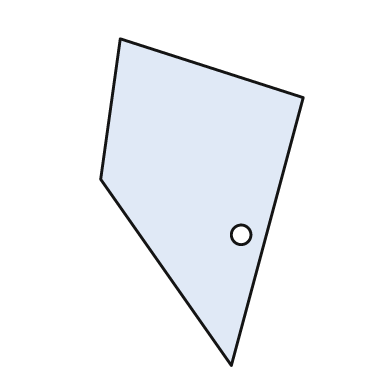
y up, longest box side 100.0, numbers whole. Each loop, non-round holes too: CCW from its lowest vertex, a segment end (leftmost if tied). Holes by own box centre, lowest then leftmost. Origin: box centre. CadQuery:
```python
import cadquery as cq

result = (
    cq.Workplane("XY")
    .moveTo(9.0, -50.0)
    .lineTo(31.0, 32.0)
    .lineTo(-25.0, 50.0)
    .lineTo(-31.0, 7.0)
    .close()
    .moveTo(12.0, -10.0)
    .circle(3.0)
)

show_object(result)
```